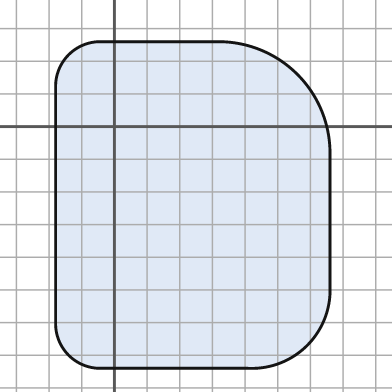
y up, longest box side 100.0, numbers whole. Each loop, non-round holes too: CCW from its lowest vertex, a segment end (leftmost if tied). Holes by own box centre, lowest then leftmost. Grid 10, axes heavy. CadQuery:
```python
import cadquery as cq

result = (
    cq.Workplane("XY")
    .moveTo(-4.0, -74.0)
    .lineTo(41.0, -74.0)
    .threePointArc((59.0, -67.0), (66.0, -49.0))
    .lineTo(66.0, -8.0)
    .threePointArc((56.0, 16.0), (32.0, 26.0))
    .lineTo(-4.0, 26.0)
    .threePointArc((-14.0, 22.0), (-18.0, 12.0))
    .lineTo(-18.0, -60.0)
    .threePointArc((-14.0, -70.0), (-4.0, -74.0))
    .close()
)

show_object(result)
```